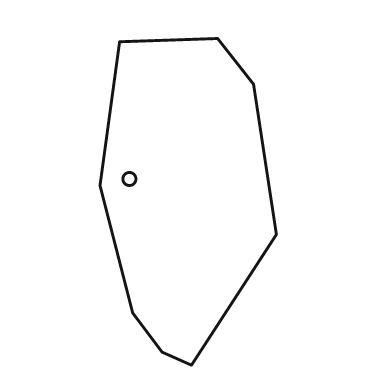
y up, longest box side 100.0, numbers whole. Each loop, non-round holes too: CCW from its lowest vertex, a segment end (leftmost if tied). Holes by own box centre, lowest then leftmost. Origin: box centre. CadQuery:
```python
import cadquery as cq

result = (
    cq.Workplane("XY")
    .moveTo(1.0, -50.0)
    .lineTo(27.0, -10.0)
    .lineTo(20.0, 36.0)
    .lineTo(9.0, 50.0)
    .lineTo(-21.0, 49.0)
    .lineTo(-27.0, 5.0)
    .lineTo(-17.0, -34.0)
    .lineTo(-8.0, -46.0)
    .close()
    .moveTo(-18.0, 7.0)
    .circle(2.0)
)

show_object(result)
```